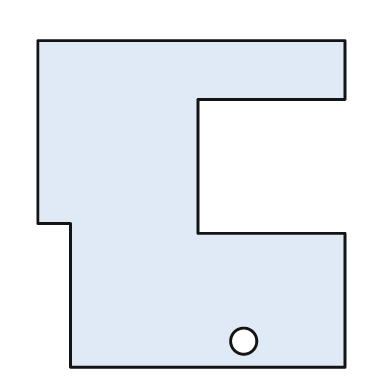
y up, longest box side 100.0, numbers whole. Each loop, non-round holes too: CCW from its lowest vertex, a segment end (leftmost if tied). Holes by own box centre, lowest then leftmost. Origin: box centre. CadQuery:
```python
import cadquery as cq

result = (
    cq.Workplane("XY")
    .moveTo(-37.0, -50.0)
    .lineTo(47.0, -50.0)
    .lineTo(47.0, -9.0)
    .lineTo(2.0, -9.0)
    .lineTo(2.0, 32.0)
    .lineTo(47.0, 32.0)
    .lineTo(47.0, 50.0)
    .lineTo(-47.0, 50.0)
    .lineTo(-47.0, -6.0)
    .lineTo(-37.0, -6.0)
    .close()
    .moveTo(16.0, -42.0)
    .circle(4.0)
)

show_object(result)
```